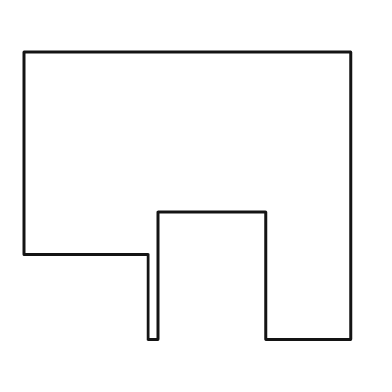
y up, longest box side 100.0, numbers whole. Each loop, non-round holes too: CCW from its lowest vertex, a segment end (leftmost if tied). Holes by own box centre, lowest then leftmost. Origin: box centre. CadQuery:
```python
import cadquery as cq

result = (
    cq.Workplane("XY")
    .moveTo(-12.0, -44.0)
    .lineTo(-9.0, -44.0)
    .lineTo(-9.0, -5.0)
    .lineTo(24.0, -5.0)
    .lineTo(24.0, -44.0)
    .lineTo(50.0, -44.0)
    .lineTo(50.0, 44.0)
    .lineTo(-50.0, 44.0)
    .lineTo(-50.0, -18.0)
    .lineTo(-12.0, -18.0)
    .close()
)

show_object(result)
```